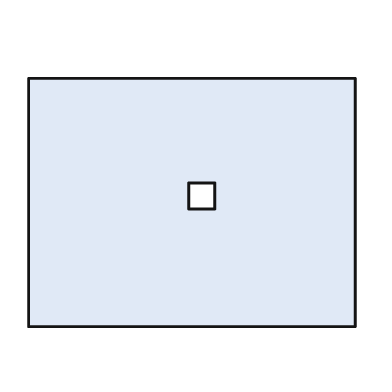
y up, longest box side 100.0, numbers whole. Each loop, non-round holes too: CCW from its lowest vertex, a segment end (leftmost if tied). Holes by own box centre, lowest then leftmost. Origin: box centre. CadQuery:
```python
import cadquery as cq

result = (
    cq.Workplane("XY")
    .moveTo(-50.0, -38.0)
    .lineTo(50.0, -38.0)
    .lineTo(50.0, 38.0)
    .lineTo(-50.0, 38.0)
    .close()
    .moveTo(-1.0, -2.0)
    .lineTo(7.0, -2.0)
    .lineTo(7.0, 6.0)
    .lineTo(-1.0, 6.0)
    .close()
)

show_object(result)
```